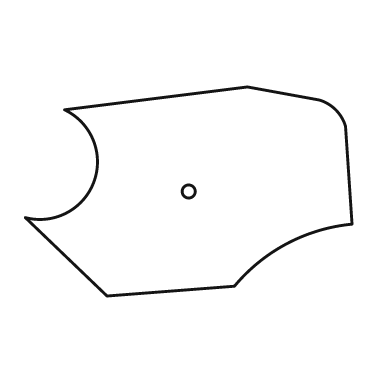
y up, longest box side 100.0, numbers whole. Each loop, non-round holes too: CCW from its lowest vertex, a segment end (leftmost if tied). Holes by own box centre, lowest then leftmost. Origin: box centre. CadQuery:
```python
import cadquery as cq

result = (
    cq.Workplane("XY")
    .moveTo(-25.0, -32.0)
    .lineTo(14.0, -29.0)
    .threePointArc((30.0, -16.0), (50.0, -10.0))
    .lineTo(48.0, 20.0)
    .threePointArc((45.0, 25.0), (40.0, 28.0))
    .lineTo(18.0, 32.0)
    .lineTo(-38.0, 25.0)
    .threePointArc((-29.0, 3.0), (-50.0, -8.0))
    .close()
    .moveTo(0.0, 0.0)
    .circle(2.0)
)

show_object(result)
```